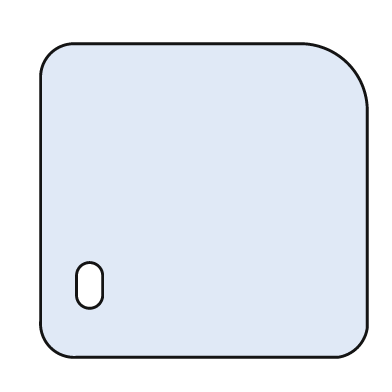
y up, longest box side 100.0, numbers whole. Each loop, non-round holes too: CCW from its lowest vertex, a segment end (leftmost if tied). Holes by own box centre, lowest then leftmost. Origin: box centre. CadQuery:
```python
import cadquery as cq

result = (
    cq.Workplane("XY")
    .moveTo(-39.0, -48.0)
    .lineTo(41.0, -48.0)
    .threePointArc((47.0, -45.0), (50.0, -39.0))
    .lineTo(50.0, 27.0)
    .threePointArc((44.0, 42.0), (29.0, 48.0))
    .lineTo(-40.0, 48.0)
    .threePointArc((-47.0, 45.0), (-50.0, 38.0))
    .lineTo(-50.0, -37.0)
    .threePointArc((-47.0, -45.0), (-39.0, -48.0))
    .close()
    .moveTo(-39.0, -29.0)
    .threePointArc((-35.0, -33.0), (-31.0, -29.0))
    .lineTo(-31.0, -23.0)
    .threePointArc((-35.0, -19.0), (-39.0, -23.0))
    .close()
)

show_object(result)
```